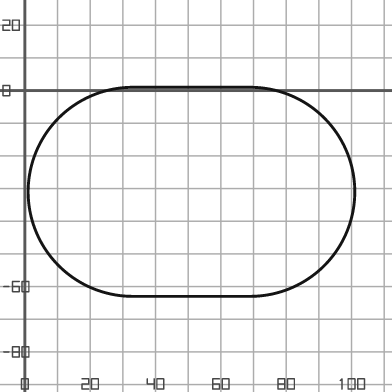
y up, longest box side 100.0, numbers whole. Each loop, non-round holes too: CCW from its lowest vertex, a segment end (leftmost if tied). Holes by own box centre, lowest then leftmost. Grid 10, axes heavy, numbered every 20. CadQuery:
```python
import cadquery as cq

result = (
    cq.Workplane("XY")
    .moveTo(33.0, -63.0)
    .lineTo(69.0, -63.0)
    .threePointArc((101.0, -31.0), (69.0, 1.0))
    .lineTo(33.0, 1.0)
    .threePointArc((1.0, -31.0), (33.0, -63.0))
    .close()
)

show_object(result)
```